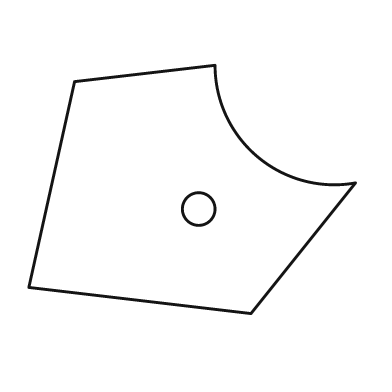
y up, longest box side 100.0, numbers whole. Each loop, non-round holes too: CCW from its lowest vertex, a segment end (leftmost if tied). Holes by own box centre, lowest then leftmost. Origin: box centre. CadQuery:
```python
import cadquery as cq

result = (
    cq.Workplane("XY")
    .moveTo(18.0, -38.0)
    .lineTo(50.0, 2.0)
    .threePointArc((20.0, 10.0), (7.0, 38.0))
    .lineTo(-36.0, 33.0)
    .lineTo(-50.0, -30.0)
    .close()
    .moveTo(2.0, -6.0)
    .circle(5.0)
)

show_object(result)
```